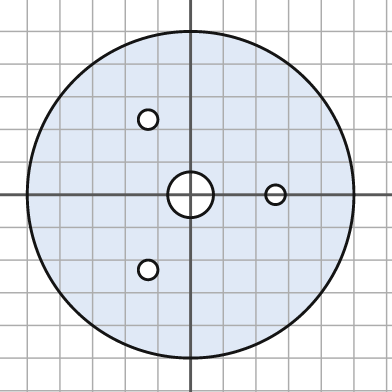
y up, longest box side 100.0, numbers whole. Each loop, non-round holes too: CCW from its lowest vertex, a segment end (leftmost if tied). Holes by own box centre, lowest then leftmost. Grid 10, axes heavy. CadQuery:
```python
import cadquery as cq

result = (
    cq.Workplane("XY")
    .moveTo(0.0, 0.0)
    .circle(50.0)
    .moveTo(-13.0, -23.0)
    .circle(3.0)
    .moveTo(0.0, 0.0)
    .circle(7.0)
    .moveTo(26.0, 0.0)
    .circle(3.0)
    .moveTo(-13.0, 23.0)
    .circle(3.0)
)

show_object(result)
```